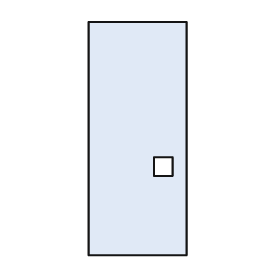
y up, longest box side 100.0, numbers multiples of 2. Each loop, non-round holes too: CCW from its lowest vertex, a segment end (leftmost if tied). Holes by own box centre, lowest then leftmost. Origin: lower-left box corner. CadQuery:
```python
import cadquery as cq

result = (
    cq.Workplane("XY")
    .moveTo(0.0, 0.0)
    .lineTo(42.0, 0.0)
    .lineTo(42.0, 100.0)
    .lineTo(0.0, 100.0)
    .close()
    .moveTo(28.0, 34.0)
    .lineTo(36.0, 34.0)
    .lineTo(36.0, 42.0)
    .lineTo(28.0, 42.0)
    .close()
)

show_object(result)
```